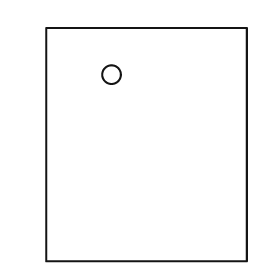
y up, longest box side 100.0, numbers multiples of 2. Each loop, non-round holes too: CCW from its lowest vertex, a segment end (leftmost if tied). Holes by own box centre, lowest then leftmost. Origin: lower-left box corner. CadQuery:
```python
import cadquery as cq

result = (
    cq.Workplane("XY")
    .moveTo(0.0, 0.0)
    .lineTo(86.0, 0.0)
    .lineTo(86.0, 100.0)
    .lineTo(0.0, 100.0)
    .close()
    .moveTo(28.0, 80.0)
    .circle(4.0)
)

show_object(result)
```